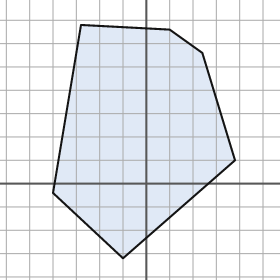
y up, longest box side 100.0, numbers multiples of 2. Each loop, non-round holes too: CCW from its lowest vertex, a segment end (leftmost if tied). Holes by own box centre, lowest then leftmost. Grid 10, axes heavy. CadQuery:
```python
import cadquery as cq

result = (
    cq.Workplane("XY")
    .moveTo(-10.0, -32.0)
    .lineTo(38.0, 10.0)
    .lineTo(24.0, 56.0)
    .lineTo(10.0, 66.0)
    .lineTo(-28.0, 68.0)
    .lineTo(-40.0, -4.0)
    .close()
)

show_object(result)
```